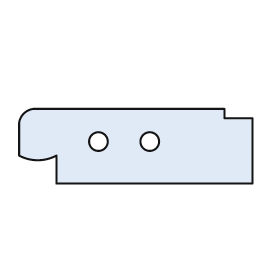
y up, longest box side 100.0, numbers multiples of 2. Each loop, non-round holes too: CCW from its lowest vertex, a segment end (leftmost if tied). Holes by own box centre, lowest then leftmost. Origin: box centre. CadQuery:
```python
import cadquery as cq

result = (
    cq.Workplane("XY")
    .moveTo(-34.0, -16.0)
    .lineTo(50.0, -16.0)
    .lineTo(50.0, 12.0)
    .lineTo(38.0, 12.0)
    .lineTo(38.0, 16.0)
    .lineTo(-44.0, 16.0)
    .threePointArc((-48.0, 14.0), (-50.0, 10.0))
    .lineTo(-50.0, -4.0)
    .threePointArc((-42.0, -6.0), (-34.0, -4.0))
    .close()
    .moveTo(-16.0, 2.0)
    .circle(4.0)
    .moveTo(6.0, 2.0)
    .circle(4.0)
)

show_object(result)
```